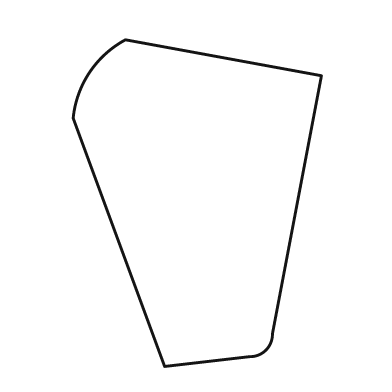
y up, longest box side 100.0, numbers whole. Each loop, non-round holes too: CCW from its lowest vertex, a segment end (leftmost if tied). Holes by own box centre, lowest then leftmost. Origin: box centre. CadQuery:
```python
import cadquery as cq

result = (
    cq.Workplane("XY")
    .moveTo(-10.0, -50.0)
    .lineTo(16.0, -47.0)
    .threePointArc((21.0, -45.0), (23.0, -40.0))
    .lineTo(38.0, 39.0)
    .lineTo(-22.0, 50.0)
    .threePointArc((-33.0, 40.0), (-38.0, 26.0))
    .close()
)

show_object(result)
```